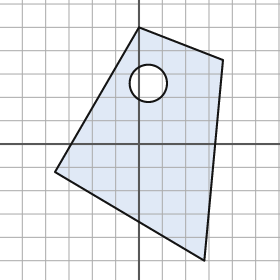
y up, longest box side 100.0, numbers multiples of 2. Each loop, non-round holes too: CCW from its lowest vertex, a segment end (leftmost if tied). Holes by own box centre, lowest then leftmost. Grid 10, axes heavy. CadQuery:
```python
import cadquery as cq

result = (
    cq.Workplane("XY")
    .moveTo(28.0, -50.0)
    .lineTo(36.0, 36.0)
    .lineTo(0.0, 50.0)
    .lineTo(-36.0, -12.0)
    .close()
    .moveTo(4.0, 26.0)
    .circle(8.0)
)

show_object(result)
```